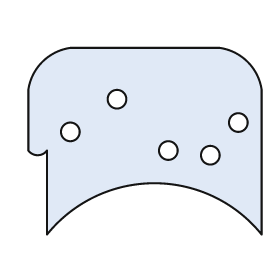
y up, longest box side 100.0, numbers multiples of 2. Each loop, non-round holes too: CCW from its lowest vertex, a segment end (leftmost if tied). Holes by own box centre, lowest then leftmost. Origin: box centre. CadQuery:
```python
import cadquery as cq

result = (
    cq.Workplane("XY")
    .moveTo(-42.0, -40.0)
    .threePointArc((4.0, -18.0), (50.0, -40.0))
    .lineTo(50.0, 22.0)
    .threePointArc((44.0, 34.0), (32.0, 40.0))
    .lineTo(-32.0, 40.0)
    .threePointArc((-44.0, 34.0), (-50.0, 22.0))
    .lineTo(-50.0, -4.0)
    .threePointArc((-46.0, -6.0), (-42.0, -4.0))
    .close()
    .moveTo(28.0, -6.0)
    .circle(4.0)
    .moveTo(10.0, -4.0)
    .circle(4.0)
    .moveTo(-32.0, 4.0)
    .circle(4.0)
    .moveTo(40.0, 8.0)
    .circle(4.0)
    .moveTo(-12.0, 18.0)
    .circle(4.0)
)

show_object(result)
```